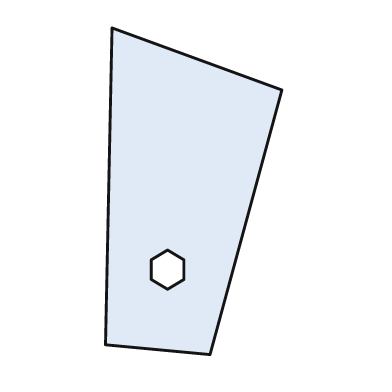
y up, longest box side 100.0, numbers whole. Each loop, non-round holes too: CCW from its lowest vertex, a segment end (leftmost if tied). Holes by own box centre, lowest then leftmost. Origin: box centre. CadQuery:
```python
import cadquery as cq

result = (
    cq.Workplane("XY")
    .moveTo(5.0, -50.0)
    .lineTo(27.0, 31.0)
    .lineTo(-25.0, 50.0)
    .lineTo(-27.0, -47.0)
    .close()
    .moveTo(-8.0, -30.0)
    .lineTo(-3.0, -27.0)
    .lineTo(-3.0, -21.0)
    .lineTo(-8.0, -18.0)
    .lineTo(-13.0, -21.0)
    .lineTo(-13.0, -27.0)
    .close()
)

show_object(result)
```